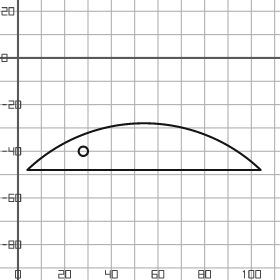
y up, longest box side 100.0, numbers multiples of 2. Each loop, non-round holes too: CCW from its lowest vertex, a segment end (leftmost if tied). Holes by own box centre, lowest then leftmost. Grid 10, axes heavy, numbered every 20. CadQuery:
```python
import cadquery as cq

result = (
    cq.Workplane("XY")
    .moveTo(4.0, -48.0)
    .lineTo(104.0, -48.0)
    .threePointArc((54.0, -28.0), (4.0, -48.0))
    .close()
    .moveTo(28.0, -40.0)
    .circle(2.0)
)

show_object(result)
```